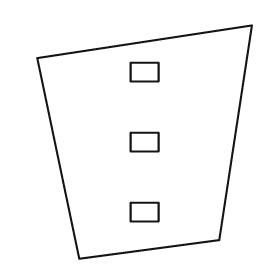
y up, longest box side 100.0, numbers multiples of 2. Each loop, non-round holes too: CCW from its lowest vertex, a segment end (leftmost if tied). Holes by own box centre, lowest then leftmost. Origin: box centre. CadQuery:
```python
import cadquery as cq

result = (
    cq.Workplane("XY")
    .moveTo(-28.0, -50.0)
    .lineTo(32.0, -42.0)
    .lineTo(46.0, 50.0)
    .lineTo(-46.0, 36.0)
    .close()
    .moveTo(-6.0, -34.0)
    .lineTo(6.0, -34.0)
    .lineTo(6.0, -26.0)
    .lineTo(-6.0, -26.0)
    .close()
    .moveTo(-6.0, -4.0)
    .lineTo(6.0, -4.0)
    .lineTo(6.0, 4.0)
    .lineTo(-6.0, 4.0)
    .close()
    .moveTo(-6.0, 26.0)
    .lineTo(6.0, 26.0)
    .lineTo(6.0, 34.0)
    .lineTo(-6.0, 34.0)
    .close()
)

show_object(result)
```